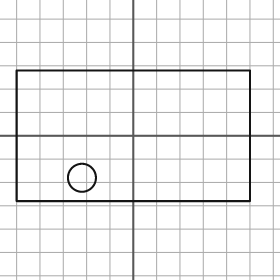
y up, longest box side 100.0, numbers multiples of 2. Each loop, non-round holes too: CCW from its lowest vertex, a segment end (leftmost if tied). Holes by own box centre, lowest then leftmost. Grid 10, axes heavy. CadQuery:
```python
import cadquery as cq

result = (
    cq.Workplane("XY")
    .moveTo(-50.0, -28.0)
    .lineTo(50.0, -28.0)
    .lineTo(50.0, 28.0)
    .lineTo(-50.0, 28.0)
    .close()
    .moveTo(-22.0, -18.0)
    .circle(6.0)
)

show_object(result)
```